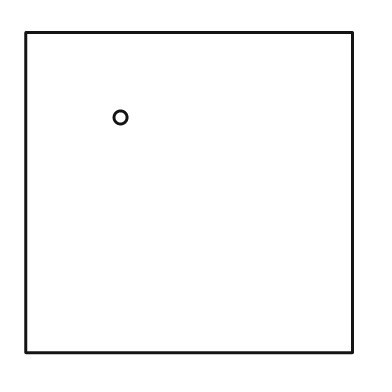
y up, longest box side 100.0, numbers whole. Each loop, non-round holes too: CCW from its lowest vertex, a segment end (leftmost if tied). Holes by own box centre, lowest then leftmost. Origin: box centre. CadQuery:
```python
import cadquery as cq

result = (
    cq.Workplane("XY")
    .moveTo(-50.0, -49.0)
    .lineTo(50.0, -49.0)
    .lineTo(50.0, 49.0)
    .lineTo(-50.0, 49.0)
    .close()
    .moveTo(-21.0, 23.0)
    .circle(2.0)
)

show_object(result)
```